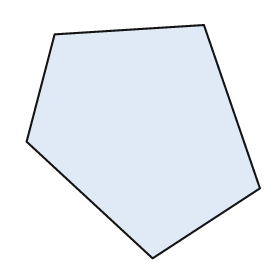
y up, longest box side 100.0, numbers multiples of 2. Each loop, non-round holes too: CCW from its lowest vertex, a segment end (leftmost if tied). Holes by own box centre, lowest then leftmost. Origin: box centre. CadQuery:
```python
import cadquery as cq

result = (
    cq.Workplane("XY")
    .moveTo(4.0, -50.0)
    .lineTo(50.0, -20.0)
    .lineTo(26.0, 50.0)
    .lineTo(-38.0, 46.0)
    .lineTo(-50.0, 0.0)
    .close()
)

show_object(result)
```